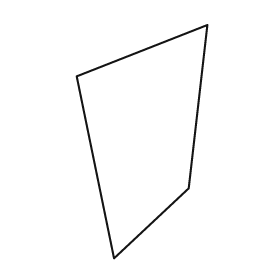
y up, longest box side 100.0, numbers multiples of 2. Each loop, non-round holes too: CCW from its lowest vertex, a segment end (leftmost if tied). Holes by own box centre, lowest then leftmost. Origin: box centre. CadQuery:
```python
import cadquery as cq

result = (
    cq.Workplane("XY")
    .moveTo(-12.0, -50.0)
    .lineTo(20.0, -20.0)
    .lineTo(28.0, 50.0)
    .lineTo(-28.0, 28.0)
    .close()
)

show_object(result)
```